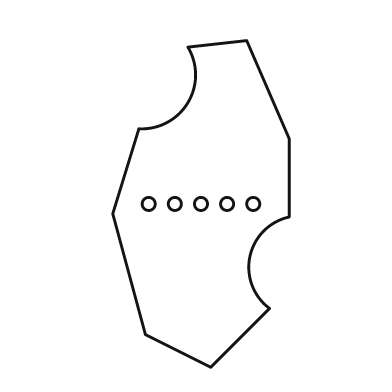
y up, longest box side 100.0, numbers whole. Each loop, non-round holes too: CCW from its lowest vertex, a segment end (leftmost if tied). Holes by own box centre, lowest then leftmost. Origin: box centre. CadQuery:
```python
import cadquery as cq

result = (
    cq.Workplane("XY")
    .moveTo(3.0, -50.0)
    .lineTo(21.0, -32.0)
    .threePointArc((15.0, -16.0), (27.0, -4.0))
    .lineTo(27.0, 20.0)
    .lineTo(14.0, 50.0)
    .lineTo(-4.0, 48.0)
    .threePointArc((-4.0, 31.0), (-19.0, 23.0))
    .lineTo(-27.0, -3.0)
    .lineTo(-17.0, -40.0)
    .close()
    .moveTo(-16.0, 0.0)
    .circle(2.0)
    .moveTo(-8.0, 0.0)
    .circle(2.0)
    .moveTo(0.0, 0.0)
    .circle(2.0)
    .moveTo(8.0, 0.0)
    .circle(2.0)
    .moveTo(16.0, 0.0)
    .circle(2.0)
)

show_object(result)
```